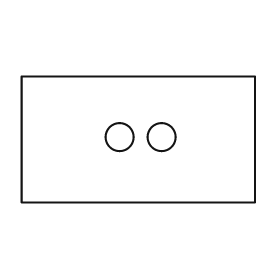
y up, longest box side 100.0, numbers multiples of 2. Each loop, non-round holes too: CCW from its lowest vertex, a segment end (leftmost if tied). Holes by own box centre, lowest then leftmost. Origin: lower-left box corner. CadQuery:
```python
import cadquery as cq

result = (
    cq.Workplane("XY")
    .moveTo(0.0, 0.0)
    .lineTo(100.0, 0.0)
    .lineTo(100.0, 54.0)
    .lineTo(0.0, 54.0)
    .close()
    .moveTo(42.0, 28.0)
    .circle(6.0)
    .moveTo(60.0, 28.0)
    .circle(6.0)
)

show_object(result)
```